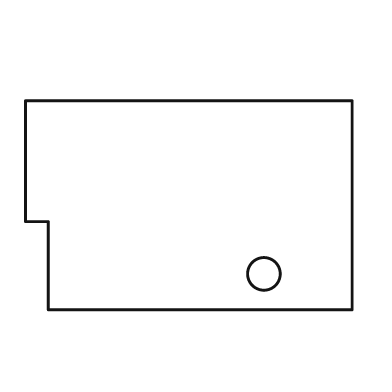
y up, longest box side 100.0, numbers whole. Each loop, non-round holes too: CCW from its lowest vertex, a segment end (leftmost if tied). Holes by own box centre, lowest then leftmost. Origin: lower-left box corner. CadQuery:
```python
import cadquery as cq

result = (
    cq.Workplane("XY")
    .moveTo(7.0, 0.0)
    .lineTo(100.0, 0.0)
    .lineTo(100.0, 64.0)
    .lineTo(0.0, 64.0)
    .lineTo(0.0, 27.0)
    .lineTo(7.0, 27.0)
    .close()
    .moveTo(73.0, 11.0)
    .circle(5.0)
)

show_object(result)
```